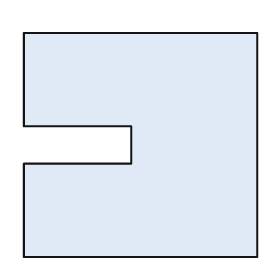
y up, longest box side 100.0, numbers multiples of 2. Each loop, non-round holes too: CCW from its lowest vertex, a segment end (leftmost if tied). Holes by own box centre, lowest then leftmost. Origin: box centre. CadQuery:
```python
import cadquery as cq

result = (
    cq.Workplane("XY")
    .moveTo(-50.0, -48.0)
    .lineTo(50.0, -48.0)
    .lineTo(50.0, 48.0)
    .lineTo(-50.0, 48.0)
    .lineTo(-50.0, 8.0)
    .lineTo(-4.0, 8.0)
    .lineTo(-4.0, -8.0)
    .lineTo(-50.0, -8.0)
    .close()
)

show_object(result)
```